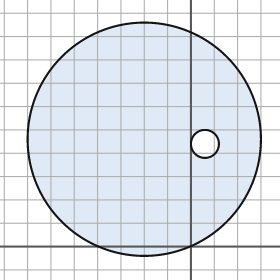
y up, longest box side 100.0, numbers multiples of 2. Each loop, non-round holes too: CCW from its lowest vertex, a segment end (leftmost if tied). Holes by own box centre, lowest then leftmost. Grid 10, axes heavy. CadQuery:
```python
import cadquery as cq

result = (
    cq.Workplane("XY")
    .moveTo(-20.0, 46.0)
    .circle(50.0)
    .moveTo(6.0, 44.0)
    .circle(6.0)
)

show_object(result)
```